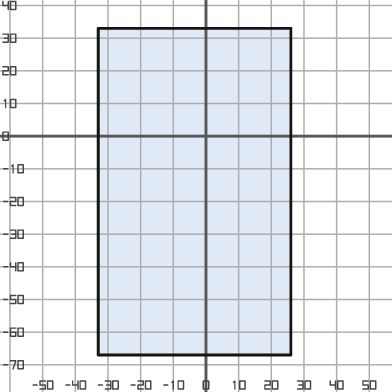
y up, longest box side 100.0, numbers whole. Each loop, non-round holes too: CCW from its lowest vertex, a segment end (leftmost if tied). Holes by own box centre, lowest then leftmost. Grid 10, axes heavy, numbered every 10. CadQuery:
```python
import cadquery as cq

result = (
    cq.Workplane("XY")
    .moveTo(-33.0, -67.0)
    .lineTo(26.0, -67.0)
    .lineTo(26.0, 33.0)
    .lineTo(-33.0, 33.0)
    .close()
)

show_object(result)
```